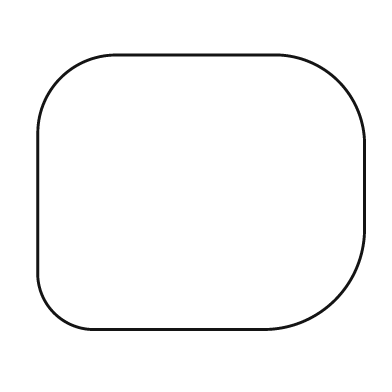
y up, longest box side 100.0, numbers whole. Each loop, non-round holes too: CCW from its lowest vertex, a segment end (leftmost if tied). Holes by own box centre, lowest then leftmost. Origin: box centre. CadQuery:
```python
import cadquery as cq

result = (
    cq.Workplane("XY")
    .moveTo(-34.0, -42.0)
    .lineTo(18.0, -42.0)
    .threePointArc((41.0, -33.0), (50.0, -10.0))
    .lineTo(50.0, 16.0)
    .threePointArc((42.0, 34.0), (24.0, 42.0))
    .lineTo(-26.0, 42.0)
    .threePointArc((-43.0, 35.0), (-50.0, 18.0))
    .lineTo(-50.0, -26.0)
    .threePointArc((-45.0, -37.0), (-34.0, -42.0))
    .close()
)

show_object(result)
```